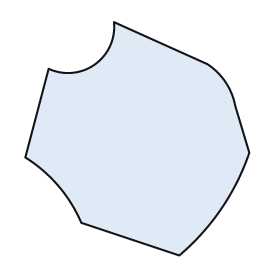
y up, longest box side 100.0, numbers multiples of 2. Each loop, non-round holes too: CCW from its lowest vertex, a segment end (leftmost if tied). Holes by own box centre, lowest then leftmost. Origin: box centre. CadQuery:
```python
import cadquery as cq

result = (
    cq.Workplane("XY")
    .moveTo(18.0, -50.0)
    .threePointArc((36.0, -30.0), (48.0, -6.0))
    .lineTo(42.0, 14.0)
    .threePointArc((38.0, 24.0), (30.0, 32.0))
    .lineTo(-10.0, 50.0)
    .threePointArc((-18.0, 32.0), (-38.0, 30.0))
    .lineTo(-48.0, -8.0)
    .threePointArc((-34.0, -20.0), (-24.0, -36.0))
    .close()
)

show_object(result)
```